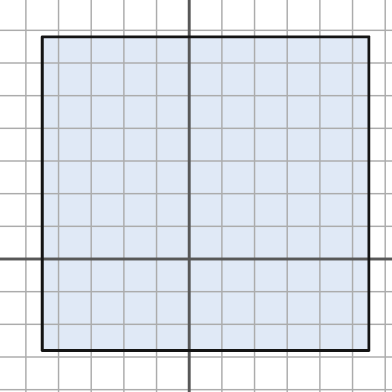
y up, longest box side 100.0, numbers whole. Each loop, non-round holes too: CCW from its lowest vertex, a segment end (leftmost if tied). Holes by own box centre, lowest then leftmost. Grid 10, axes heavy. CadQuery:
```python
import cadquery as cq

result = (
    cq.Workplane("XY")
    .moveTo(-45.0, -28.0)
    .lineTo(55.0, -28.0)
    .lineTo(55.0, 68.0)
    .lineTo(-45.0, 68.0)
    .close()
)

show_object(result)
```